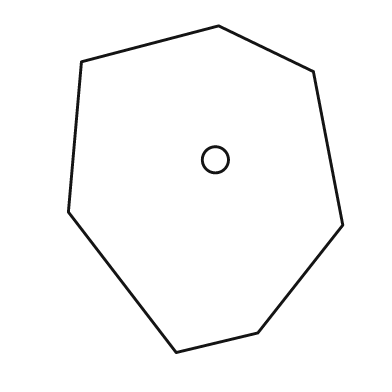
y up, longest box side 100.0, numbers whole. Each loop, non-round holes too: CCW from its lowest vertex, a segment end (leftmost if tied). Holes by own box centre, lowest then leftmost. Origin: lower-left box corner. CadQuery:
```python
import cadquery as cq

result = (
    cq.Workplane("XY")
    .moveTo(33.0, 0.0)
    .lineTo(58.0, 6.0)
    .lineTo(84.0, 39.0)
    .lineTo(75.0, 86.0)
    .lineTo(46.0, 100.0)
    .lineTo(4.0, 89.0)
    .lineTo(0.0, 43.0)
    .close()
    .moveTo(45.0, 59.0)
    .circle(4.0)
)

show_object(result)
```